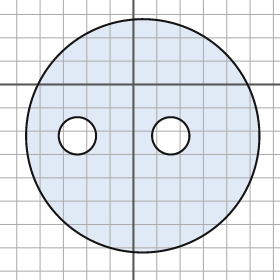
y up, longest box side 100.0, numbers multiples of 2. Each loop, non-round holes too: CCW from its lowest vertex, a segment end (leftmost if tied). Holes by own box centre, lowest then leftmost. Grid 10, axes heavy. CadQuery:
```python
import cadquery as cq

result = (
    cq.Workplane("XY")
    .moveTo(4.0, -22.0)
    .circle(50.0)
    .moveTo(-24.0, -22.0)
    .circle(8.0)
    .moveTo(16.0, -22.0)
    .circle(8.0)
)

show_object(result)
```